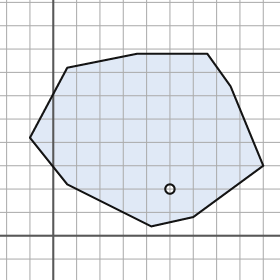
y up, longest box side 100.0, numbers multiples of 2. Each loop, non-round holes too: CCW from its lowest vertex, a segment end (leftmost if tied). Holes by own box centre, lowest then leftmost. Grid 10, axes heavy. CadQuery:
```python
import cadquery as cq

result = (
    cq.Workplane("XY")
    .moveTo(42.0, 4.0)
    .lineTo(60.0, 8.0)
    .lineTo(90.0, 30.0)
    .lineTo(76.0, 64.0)
    .lineTo(66.0, 78.0)
    .lineTo(36.0, 78.0)
    .lineTo(6.0, 72.0)
    .lineTo(-10.0, 42.0)
    .lineTo(6.0, 22.0)
    .close()
    .moveTo(50.0, 20.0)
    .circle(2.0)
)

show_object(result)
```